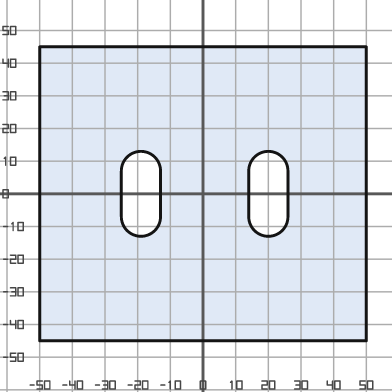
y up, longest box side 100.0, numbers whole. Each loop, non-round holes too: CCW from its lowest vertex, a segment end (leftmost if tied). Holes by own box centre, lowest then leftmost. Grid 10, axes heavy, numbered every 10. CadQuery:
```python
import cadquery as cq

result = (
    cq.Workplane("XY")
    .moveTo(-50.0, -45.0)
    .lineTo(50.0, -45.0)
    .lineTo(50.0, 45.0)
    .lineTo(-50.0, 45.0)
    .close()
    .moveTo(-25.0, -7.0)
    .threePointArc((-19.0, -13.0), (-13.0, -7.0))
    .lineTo(-13.0, 7.0)
    .threePointArc((-19.0, 13.0), (-25.0, 7.0))
    .close()
    .moveTo(14.0, -7.0)
    .threePointArc((20.0, -13.0), (26.0, -7.0))
    .lineTo(26.0, 7.0)
    .threePointArc((20.0, 13.0), (14.0, 7.0))
    .close()
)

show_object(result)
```